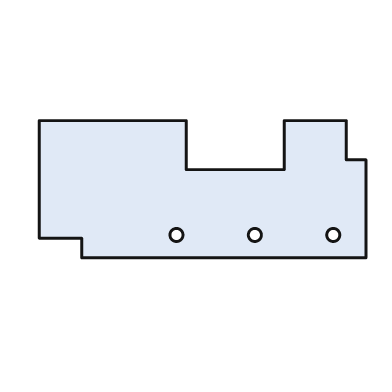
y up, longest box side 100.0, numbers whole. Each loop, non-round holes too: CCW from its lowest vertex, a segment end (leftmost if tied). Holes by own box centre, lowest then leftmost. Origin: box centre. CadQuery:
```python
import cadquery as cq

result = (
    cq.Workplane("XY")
    .moveTo(-37.0, -21.0)
    .lineTo(50.0, -21.0)
    .lineTo(50.0, 9.0)
    .lineTo(44.0, 9.0)
    .lineTo(44.0, 21.0)
    .lineTo(25.0, 21.0)
    .lineTo(25.0, 6.0)
    .lineTo(-5.0, 6.0)
    .lineTo(-5.0, 21.0)
    .lineTo(-50.0, 21.0)
    .lineTo(-50.0, -15.0)
    .lineTo(-37.0, -15.0)
    .close()
    .moveTo(-8.0, -14.0)
    .circle(2.0)
    .moveTo(16.0, -14.0)
    .circle(2.0)
    .moveTo(40.0, -14.0)
    .circle(2.0)
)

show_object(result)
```